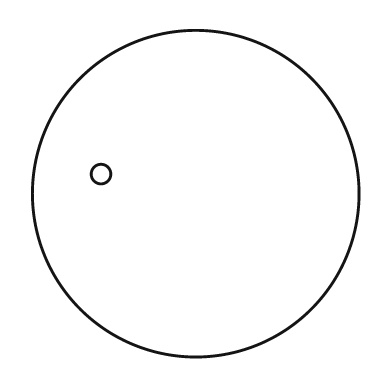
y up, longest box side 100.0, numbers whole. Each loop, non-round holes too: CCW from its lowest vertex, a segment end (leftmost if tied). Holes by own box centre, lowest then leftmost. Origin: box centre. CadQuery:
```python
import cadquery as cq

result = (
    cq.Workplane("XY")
    .moveTo(0.0, 0.0)
    .circle(50.0)
    .moveTo(-29.0, 6.0)
    .circle(3.0)
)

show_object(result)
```